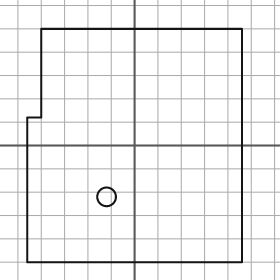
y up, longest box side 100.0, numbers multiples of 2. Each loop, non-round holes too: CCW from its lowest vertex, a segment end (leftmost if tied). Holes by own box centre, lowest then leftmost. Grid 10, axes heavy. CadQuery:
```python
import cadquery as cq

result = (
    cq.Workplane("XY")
    .moveTo(-46.0, -50.0)
    .lineTo(46.0, -50.0)
    .lineTo(46.0, 50.0)
    .lineTo(-40.0, 50.0)
    .lineTo(-40.0, 12.0)
    .lineTo(-46.0, 12.0)
    .close()
    .moveTo(-12.0, -22.0)
    .circle(4.0)
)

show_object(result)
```